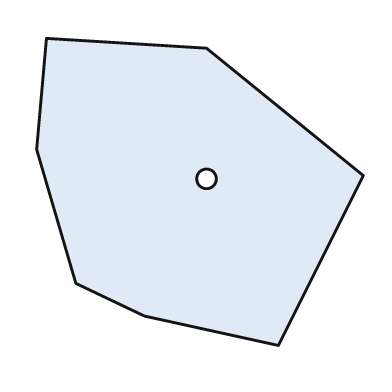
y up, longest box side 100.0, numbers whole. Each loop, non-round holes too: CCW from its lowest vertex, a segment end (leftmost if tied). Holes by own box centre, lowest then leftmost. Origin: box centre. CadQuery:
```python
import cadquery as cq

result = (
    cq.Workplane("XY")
    .moveTo(24.0, -47.0)
    .lineTo(50.0, 5.0)
    .lineTo(2.0, 44.0)
    .lineTo(-47.0, 47.0)
    .lineTo(-50.0, 13.0)
    .lineTo(-38.0, -28.0)
    .lineTo(-17.0, -38.0)
    .close()
    .moveTo(2.0, 4.0)
    .circle(3.0)
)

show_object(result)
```